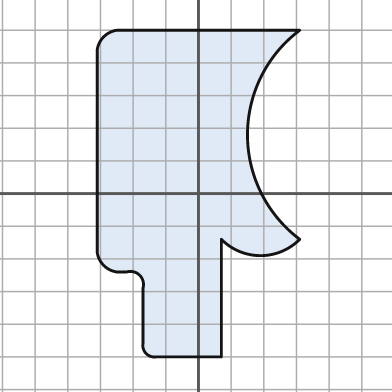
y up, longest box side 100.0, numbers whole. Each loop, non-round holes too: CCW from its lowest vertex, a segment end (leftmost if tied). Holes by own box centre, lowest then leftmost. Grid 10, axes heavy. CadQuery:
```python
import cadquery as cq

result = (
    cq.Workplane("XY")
    .moveTo(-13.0, -50.0)
    .lineTo(7.0, -50.0)
    .lineTo(7.0, -14.0)
    .threePointArc((19.0, -19.0), (31.0, -14.0))
    .threePointArc((15.0, 18.0), (31.0, 50.0))
    .lineTo(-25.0, 50.0)
    .threePointArc((-29.0, 48.0), (-31.0, 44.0))
    .lineTo(-31.0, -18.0)
    .threePointArc((-29.0, -22.0), (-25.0, -24.0))
    .lineTo(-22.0, -24.0)
    .threePointArc((-18.0, -25.0), (-17.0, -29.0))
    .lineTo(-17.0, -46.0)
    .threePointArc((-16.0, -49.0), (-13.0, -50.0))
    .close()
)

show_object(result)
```